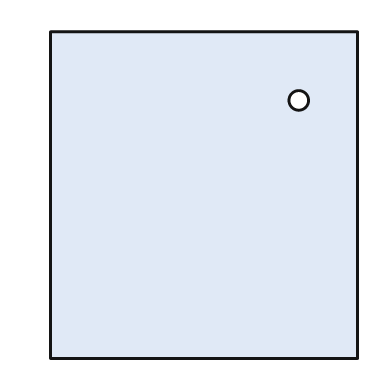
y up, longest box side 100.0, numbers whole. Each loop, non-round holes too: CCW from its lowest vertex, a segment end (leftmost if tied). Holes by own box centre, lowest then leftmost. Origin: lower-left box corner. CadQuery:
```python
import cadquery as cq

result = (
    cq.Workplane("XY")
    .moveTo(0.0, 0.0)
    .lineTo(94.0, 0.0)
    .lineTo(94.0, 100.0)
    .lineTo(0.0, 100.0)
    .close()
    .moveTo(76.0, 79.0)
    .circle(3.0)
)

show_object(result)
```